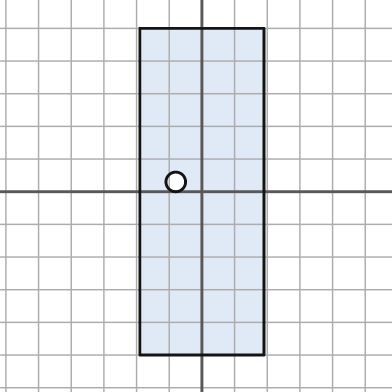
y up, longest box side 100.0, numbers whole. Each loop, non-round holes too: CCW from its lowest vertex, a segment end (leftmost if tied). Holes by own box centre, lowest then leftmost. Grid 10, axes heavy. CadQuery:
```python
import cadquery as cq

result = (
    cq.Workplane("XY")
    .moveTo(-19.0, -50.0)
    .lineTo(19.0, -50.0)
    .lineTo(19.0, 50.0)
    .lineTo(-19.0, 50.0)
    .close()
    .moveTo(-8.0, 3.0)
    .circle(3.0)
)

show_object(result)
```